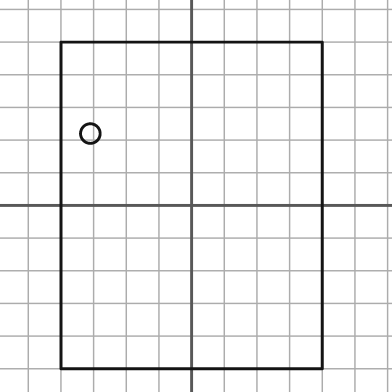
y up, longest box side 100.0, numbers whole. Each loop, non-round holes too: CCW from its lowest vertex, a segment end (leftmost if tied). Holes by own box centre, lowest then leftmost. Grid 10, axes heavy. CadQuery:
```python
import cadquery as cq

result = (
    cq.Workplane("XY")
    .moveTo(-40.0, -50.0)
    .lineTo(40.0, -50.0)
    .lineTo(40.0, 50.0)
    .lineTo(-40.0, 50.0)
    .close()
    .moveTo(-31.0, 22.0)
    .circle(3.0)
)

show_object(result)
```